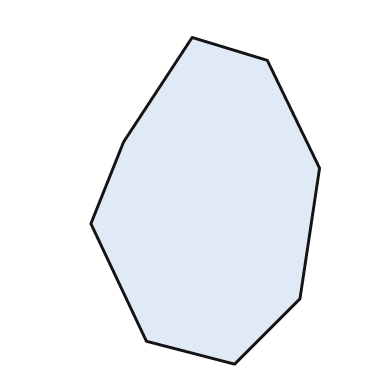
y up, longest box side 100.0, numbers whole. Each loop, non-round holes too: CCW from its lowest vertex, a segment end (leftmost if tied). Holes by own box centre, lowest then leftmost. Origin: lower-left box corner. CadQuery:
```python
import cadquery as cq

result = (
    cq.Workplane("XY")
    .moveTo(44.0, 0.0)
    .lineTo(64.0, 20.0)
    .lineTo(70.0, 60.0)
    .lineTo(54.0, 93.0)
    .lineTo(31.0, 100.0)
    .lineTo(10.0, 68.0)
    .lineTo(0.0, 43.0)
    .lineTo(17.0, 7.0)
    .close()
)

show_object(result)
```